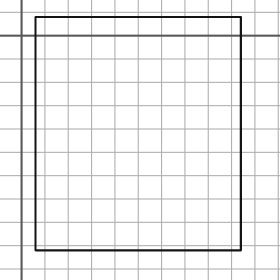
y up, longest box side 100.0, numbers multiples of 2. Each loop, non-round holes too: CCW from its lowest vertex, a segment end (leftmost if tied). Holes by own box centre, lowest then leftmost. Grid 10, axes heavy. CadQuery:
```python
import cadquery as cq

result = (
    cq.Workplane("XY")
    .moveTo(6.0, -92.0)
    .lineTo(94.0, -92.0)
    .lineTo(94.0, 8.0)
    .lineTo(6.0, 8.0)
    .close()
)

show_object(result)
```